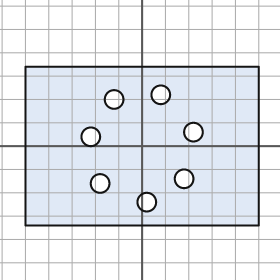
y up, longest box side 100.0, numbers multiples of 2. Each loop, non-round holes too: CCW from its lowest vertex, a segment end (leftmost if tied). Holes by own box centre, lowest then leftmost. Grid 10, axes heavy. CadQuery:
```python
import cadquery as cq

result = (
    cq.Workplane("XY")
    .moveTo(-50.0, -34.0)
    .lineTo(50.0, -34.0)
    .lineTo(50.0, 34.0)
    .lineTo(-50.0, 34.0)
    .close()
    .moveTo(2.0, -24.0)
    .circle(4.0)
    .moveTo(-18.0, -16.0)
    .circle(4.0)
    .moveTo(18.0, -14.0)
    .circle(4.0)
    .moveTo(-22.0, 4.0)
    .circle(4.0)
    .moveTo(22.0, 6.0)
    .circle(4.0)
    .moveTo(-12.0, 20.0)
    .circle(4.0)
    .moveTo(8.0, 22.0)
    .circle(4.0)
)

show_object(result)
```